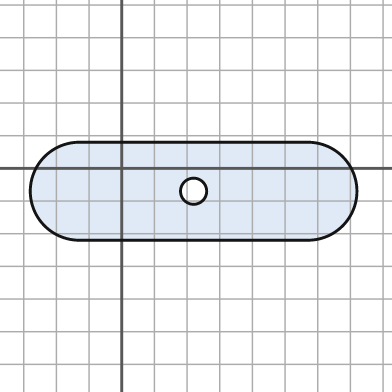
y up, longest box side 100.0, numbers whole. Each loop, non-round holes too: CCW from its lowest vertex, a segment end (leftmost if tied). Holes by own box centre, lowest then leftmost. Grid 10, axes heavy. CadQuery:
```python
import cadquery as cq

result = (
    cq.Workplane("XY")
    .moveTo(-13.0, -22.0)
    .lineTo(57.0, -22.0)
    .threePointArc((72.0, -7.0), (57.0, 8.0))
    .lineTo(-13.0, 8.0)
    .threePointArc((-28.0, -7.0), (-13.0, -22.0))
    .close()
    .moveTo(22.0, -7.0)
    .circle(4.0)
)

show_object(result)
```